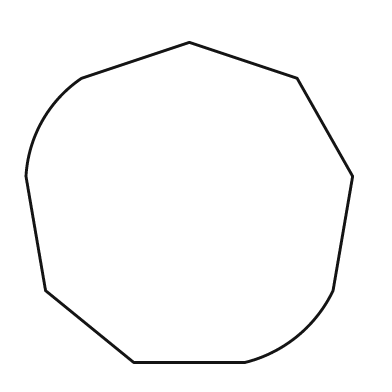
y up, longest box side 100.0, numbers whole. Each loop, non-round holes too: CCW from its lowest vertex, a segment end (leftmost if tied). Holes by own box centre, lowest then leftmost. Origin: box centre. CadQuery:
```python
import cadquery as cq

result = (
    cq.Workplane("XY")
    .moveTo(-17.0, -49.0)
    .lineTo(17.0, -49.0)
    .threePointArc((33.0, -41.0), (44.0, -27.0))
    .lineTo(50.0, 8.0)
    .lineTo(33.0, 38.0)
    .lineTo(0.0, 49.0)
    .lineTo(-33.0, 38.0)
    .threePointArc((-45.0, 25.0), (-50.0, 8.0))
    .lineTo(-44.0, -27.0)
    .close()
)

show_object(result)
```